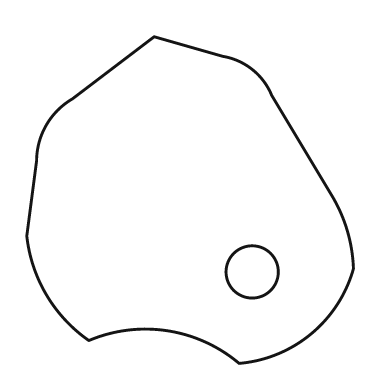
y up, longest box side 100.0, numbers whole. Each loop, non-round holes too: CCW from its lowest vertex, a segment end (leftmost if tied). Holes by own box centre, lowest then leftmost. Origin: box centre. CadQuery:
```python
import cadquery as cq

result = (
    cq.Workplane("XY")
    .moveTo(15.0, -50.0)
    .threePointArc((37.0, -41.0), (50.0, -21.0))
    .threePointArc((48.0, -9.0), (43.0, 2.0))
    .lineTo(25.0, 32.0)
    .threePointArc((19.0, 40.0), (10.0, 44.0))
    .lineTo(-11.0, 50.0)
    .lineTo(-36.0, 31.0)
    .threePointArc((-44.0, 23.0), (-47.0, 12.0))
    .lineTo(-50.0, -11.0)
    .threePointArc((-44.0, -29.0), (-31.0, -43.0))
    .threePointArc((-7.0, -40.0), (15.0, -50.0))
    .close()
    .moveTo(19.0, -22.0)
    .circle(8.0)
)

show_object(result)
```